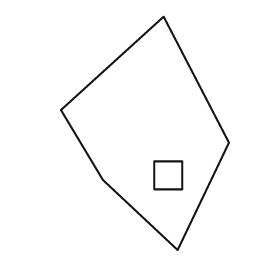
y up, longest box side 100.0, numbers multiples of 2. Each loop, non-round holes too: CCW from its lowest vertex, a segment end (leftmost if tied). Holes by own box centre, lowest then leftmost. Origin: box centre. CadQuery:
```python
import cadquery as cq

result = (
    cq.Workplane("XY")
    .moveTo(14.0, -50.0)
    .lineTo(36.0, -4.0)
    .lineTo(8.0, 50.0)
    .lineTo(-36.0, 10.0)
    .lineTo(-18.0, -20.0)
    .close()
    .moveTo(4.0, -24.0)
    .lineTo(16.0, -24.0)
    .lineTo(16.0, -12.0)
    .lineTo(4.0, -12.0)
    .close()
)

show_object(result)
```